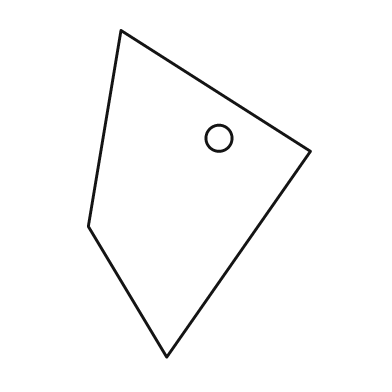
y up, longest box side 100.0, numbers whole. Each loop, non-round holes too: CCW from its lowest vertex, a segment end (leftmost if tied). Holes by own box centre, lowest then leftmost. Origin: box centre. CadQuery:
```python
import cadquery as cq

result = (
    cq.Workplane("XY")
    .moveTo(-10.0, -50.0)
    .lineTo(34.0, 13.0)
    .lineTo(-24.0, 50.0)
    .lineTo(-34.0, -10.0)
    .close()
    .moveTo(6.0, 17.0)
    .circle(4.0)
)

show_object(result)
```